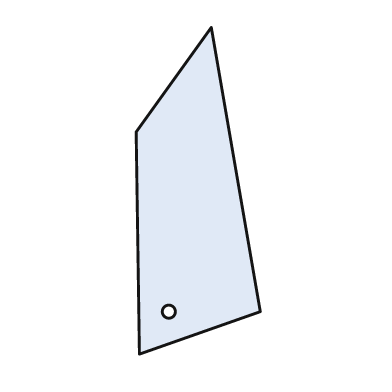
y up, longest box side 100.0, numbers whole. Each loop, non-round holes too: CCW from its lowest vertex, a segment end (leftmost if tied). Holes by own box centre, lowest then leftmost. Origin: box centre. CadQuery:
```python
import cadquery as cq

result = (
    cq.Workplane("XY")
    .moveTo(-18.0, -50.0)
    .lineTo(19.0, -37.0)
    .lineTo(4.0, 50.0)
    .lineTo(-19.0, 18.0)
    .close()
    .moveTo(-9.0, -37.0)
    .circle(2.0)
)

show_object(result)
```